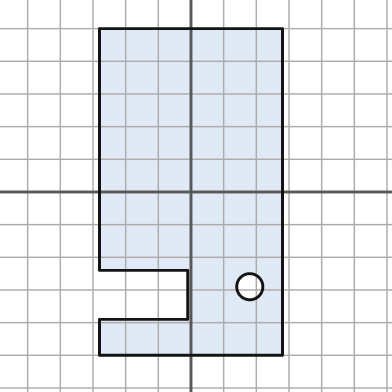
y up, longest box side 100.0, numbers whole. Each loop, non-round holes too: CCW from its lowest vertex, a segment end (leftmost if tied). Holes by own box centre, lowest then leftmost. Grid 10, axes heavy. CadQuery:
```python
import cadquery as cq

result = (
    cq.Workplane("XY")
    .moveTo(-28.0, -50.0)
    .lineTo(28.0, -50.0)
    .lineTo(28.0, 50.0)
    .lineTo(-28.0, 50.0)
    .lineTo(-28.0, -24.0)
    .lineTo(-1.0, -24.0)
    .lineTo(-1.0, -39.0)
    .lineTo(-28.0, -39.0)
    .close()
    .moveTo(18.0, -29.0)
    .circle(4.0)
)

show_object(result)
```